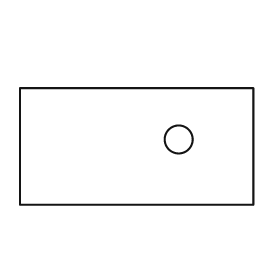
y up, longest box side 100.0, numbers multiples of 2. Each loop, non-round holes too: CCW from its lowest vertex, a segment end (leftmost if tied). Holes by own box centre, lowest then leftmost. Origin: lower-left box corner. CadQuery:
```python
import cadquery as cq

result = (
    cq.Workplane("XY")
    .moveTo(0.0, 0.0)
    .lineTo(100.0, 0.0)
    .lineTo(100.0, 50.0)
    .lineTo(0.0, 50.0)
    .close()
    .moveTo(68.0, 28.0)
    .circle(6.0)
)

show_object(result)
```